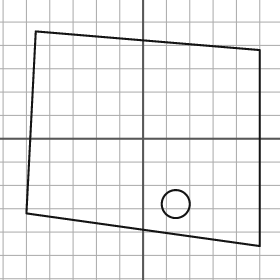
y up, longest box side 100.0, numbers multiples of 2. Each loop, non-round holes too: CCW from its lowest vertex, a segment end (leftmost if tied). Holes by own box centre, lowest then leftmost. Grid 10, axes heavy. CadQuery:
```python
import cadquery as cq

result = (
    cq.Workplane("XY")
    .moveTo(50.0, -46.0)
    .lineTo(50.0, 38.0)
    .lineTo(-46.0, 46.0)
    .lineTo(-50.0, -32.0)
    .close()
    .moveTo(14.0, -28.0)
    .circle(6.0)
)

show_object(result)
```